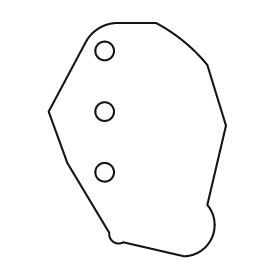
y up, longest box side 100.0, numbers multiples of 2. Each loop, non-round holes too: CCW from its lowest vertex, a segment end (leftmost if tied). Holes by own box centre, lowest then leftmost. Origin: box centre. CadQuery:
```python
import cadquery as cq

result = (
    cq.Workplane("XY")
    .moveTo(20.0, -50.0)
    .threePointArc((32.0, -42.0), (30.0, -28.0))
    .lineTo(38.0, 6.0)
    .lineTo(30.0, 32.0)
    .threePointArc((20.0, 42.0), (8.0, 50.0))
    .lineTo(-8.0, 50.0)
    .threePointArc((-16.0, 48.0), (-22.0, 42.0))
    .lineTo(-38.0, 12.0)
    .lineTo(-30.0, -10.0)
    .lineTo(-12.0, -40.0)
    .threePointArc((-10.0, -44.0), (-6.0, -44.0))
    .close()
    .moveTo(-14.0, -14.0)
    .circle(4.0)
    .moveTo(-14.0, 12.0)
    .circle(4.0)
    .moveTo(-14.0, 38.0)
    .circle(4.0)
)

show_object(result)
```